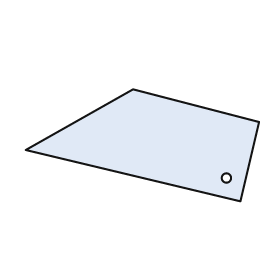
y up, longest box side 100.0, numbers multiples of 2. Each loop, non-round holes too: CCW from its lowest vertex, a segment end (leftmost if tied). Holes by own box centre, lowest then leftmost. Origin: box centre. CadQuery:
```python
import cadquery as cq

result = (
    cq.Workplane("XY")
    .moveTo(42.0, -24.0)
    .lineTo(50.0, 10.0)
    .lineTo(-4.0, 24.0)
    .lineTo(-50.0, -2.0)
    .close()
    .moveTo(36.0, -14.0)
    .circle(2.0)
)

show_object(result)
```